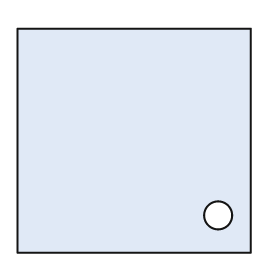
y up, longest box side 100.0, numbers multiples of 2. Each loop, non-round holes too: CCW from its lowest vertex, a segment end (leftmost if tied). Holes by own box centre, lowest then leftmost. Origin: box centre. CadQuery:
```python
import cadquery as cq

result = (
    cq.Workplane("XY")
    .moveTo(-50.0, -48.0)
    .lineTo(50.0, -48.0)
    .lineTo(50.0, 48.0)
    .lineTo(-50.0, 48.0)
    .close()
    .moveTo(36.0, -32.0)
    .circle(6.0)
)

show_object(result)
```